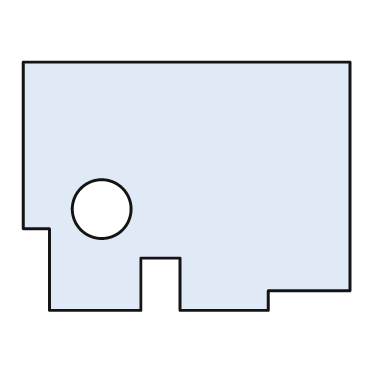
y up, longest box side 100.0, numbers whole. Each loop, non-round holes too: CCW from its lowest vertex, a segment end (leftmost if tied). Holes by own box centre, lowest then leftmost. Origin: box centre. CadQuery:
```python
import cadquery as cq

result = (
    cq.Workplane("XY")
    .moveTo(-42.0, -38.0)
    .lineTo(-14.0, -38.0)
    .lineTo(-14.0, -22.0)
    .lineTo(-2.0, -22.0)
    .lineTo(-2.0, -38.0)
    .lineTo(25.0, -38.0)
    .lineTo(25.0, -32.0)
    .lineTo(50.0, -32.0)
    .lineTo(50.0, 38.0)
    .lineTo(-50.0, 38.0)
    .lineTo(-50.0, -13.0)
    .lineTo(-42.0, -13.0)
    .close()
    .moveTo(-26.0, -7.0)
    .circle(9.0)
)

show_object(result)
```